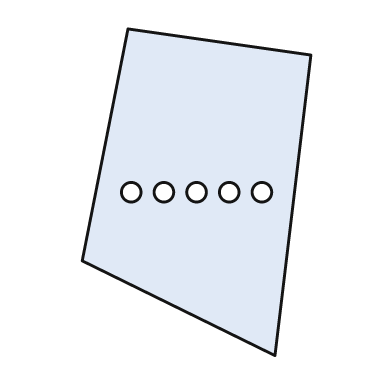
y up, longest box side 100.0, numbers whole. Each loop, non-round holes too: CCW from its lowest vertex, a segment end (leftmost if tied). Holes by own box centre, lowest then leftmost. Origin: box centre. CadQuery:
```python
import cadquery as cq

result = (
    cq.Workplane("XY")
    .moveTo(24.0, -50.0)
    .lineTo(35.0, 42.0)
    .lineTo(-21.0, 50.0)
    .lineTo(-35.0, -21.0)
    .close()
    .moveTo(-20.0, 0.0)
    .circle(3.0)
    .moveTo(-10.0, 0.0)
    .circle(3.0)
    .moveTo(0.0, 0.0)
    .circle(3.0)
    .moveTo(10.0, 0.0)
    .circle(3.0)
    .moveTo(20.0, 0.0)
    .circle(3.0)
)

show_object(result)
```